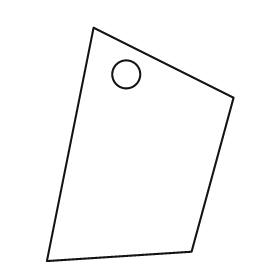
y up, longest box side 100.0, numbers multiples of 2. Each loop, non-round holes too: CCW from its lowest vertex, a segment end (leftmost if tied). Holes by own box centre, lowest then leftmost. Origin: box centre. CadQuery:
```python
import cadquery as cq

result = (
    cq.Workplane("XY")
    .moveTo(-40.0, -50.0)
    .lineTo(22.0, -46.0)
    .lineTo(40.0, 20.0)
    .lineTo(-20.0, 50.0)
    .close()
    .moveTo(-6.0, 30.0)
    .circle(6.0)
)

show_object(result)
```